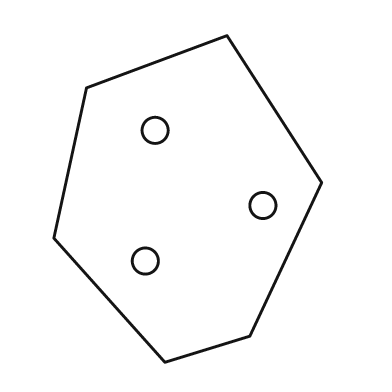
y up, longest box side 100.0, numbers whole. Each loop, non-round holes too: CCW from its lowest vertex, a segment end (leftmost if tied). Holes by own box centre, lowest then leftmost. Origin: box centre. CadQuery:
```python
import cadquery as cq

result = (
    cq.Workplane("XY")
    .moveTo(-7.0, -50.0)
    .lineTo(19.0, -42.0)
    .lineTo(41.0, 5.0)
    .lineTo(12.0, 50.0)
    .lineTo(-31.0, 34.0)
    .lineTo(-41.0, -12.0)
    .close()
    .moveTo(-13.0, -19.0)
    .circle(4.0)
    .moveTo(23.0, -2.0)
    .circle(4.0)
    .moveTo(-10.0, 21.0)
    .circle(4.0)
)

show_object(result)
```